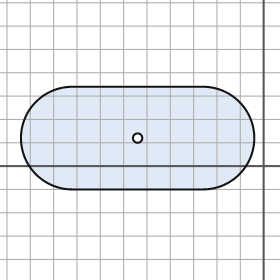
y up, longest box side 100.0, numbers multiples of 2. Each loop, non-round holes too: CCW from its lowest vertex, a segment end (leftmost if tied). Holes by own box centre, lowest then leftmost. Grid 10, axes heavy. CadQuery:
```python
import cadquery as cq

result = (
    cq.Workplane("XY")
    .moveTo(-82.0, -10.0)
    .lineTo(-26.0, -10.0)
    .threePointArc((-4.0, 12.0), (-26.0, 34.0))
    .lineTo(-82.0, 34.0)
    .threePointArc((-104.0, 12.0), (-82.0, -10.0))
    .close()
    .moveTo(-54.0, 12.0)
    .circle(2.0)
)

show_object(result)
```